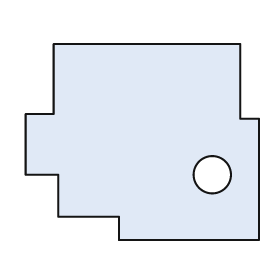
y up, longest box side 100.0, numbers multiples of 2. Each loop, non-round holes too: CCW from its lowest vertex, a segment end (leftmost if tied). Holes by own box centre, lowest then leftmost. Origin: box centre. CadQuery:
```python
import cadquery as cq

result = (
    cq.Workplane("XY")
    .moveTo(-10.0, -42.0)
    .lineTo(50.0, -42.0)
    .lineTo(50.0, 10.0)
    .lineTo(42.0, 10.0)
    .lineTo(42.0, 42.0)
    .lineTo(-38.0, 42.0)
    .lineTo(-38.0, 12.0)
    .lineTo(-50.0, 12.0)
    .lineTo(-50.0, -14.0)
    .lineTo(-36.0, -14.0)
    .lineTo(-36.0, -32.0)
    .lineTo(-10.0, -32.0)
    .close()
    .moveTo(30.0, -14.0)
    .circle(8.0)
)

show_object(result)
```